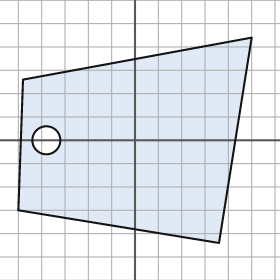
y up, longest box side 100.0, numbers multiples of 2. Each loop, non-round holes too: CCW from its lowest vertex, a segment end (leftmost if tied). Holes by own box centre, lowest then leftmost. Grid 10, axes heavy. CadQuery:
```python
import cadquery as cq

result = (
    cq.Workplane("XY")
    .moveTo(36.0, -44.0)
    .lineTo(50.0, 44.0)
    .lineTo(-48.0, 26.0)
    .lineTo(-50.0, -30.0)
    .close()
    .moveTo(-38.0, 0.0)
    .circle(6.0)
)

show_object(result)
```